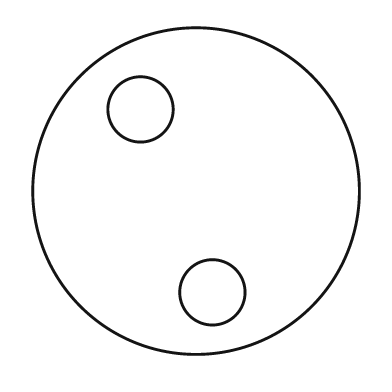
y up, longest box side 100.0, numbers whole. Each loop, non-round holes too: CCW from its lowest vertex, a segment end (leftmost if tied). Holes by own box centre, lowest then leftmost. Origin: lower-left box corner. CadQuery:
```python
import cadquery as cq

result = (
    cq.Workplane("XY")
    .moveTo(50.0, 50.0)
    .circle(50.0)
    .moveTo(55.0, 19.0)
    .circle(10.0)
    .moveTo(33.0, 75.0)
    .circle(10.0)
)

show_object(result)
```